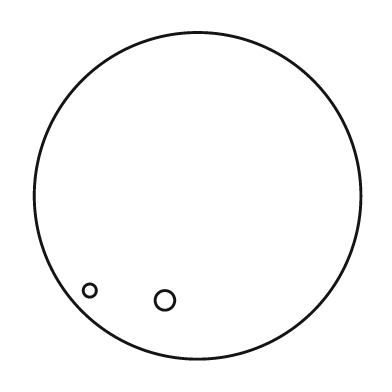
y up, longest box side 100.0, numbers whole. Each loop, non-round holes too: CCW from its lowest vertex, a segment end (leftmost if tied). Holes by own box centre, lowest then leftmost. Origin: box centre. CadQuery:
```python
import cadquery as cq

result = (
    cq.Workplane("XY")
    .moveTo(0.0, 0.0)
    .circle(50.0)
    .moveTo(-10.0, -32.0)
    .circle(3.0)
    .moveTo(-33.0, -29.0)
    .circle(2.0)
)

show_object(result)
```